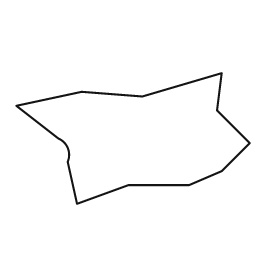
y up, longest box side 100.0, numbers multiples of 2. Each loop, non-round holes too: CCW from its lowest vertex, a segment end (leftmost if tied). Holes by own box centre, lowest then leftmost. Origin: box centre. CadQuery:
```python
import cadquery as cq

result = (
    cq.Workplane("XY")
    .moveTo(-24.0, -28.0)
    .lineTo(-2.0, -20.0)
    .lineTo(24.0, -20.0)
    .lineTo(38.0, -14.0)
    .lineTo(50.0, -2.0)
    .lineTo(36.0, 12.0)
    .lineTo(38.0, 28.0)
    .lineTo(4.0, 18.0)
    .lineTo(-22.0, 20.0)
    .lineTo(-50.0, 14.0)
    .lineTo(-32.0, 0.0)
    .threePointArc((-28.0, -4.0), (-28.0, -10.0))
    .close()
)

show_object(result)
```